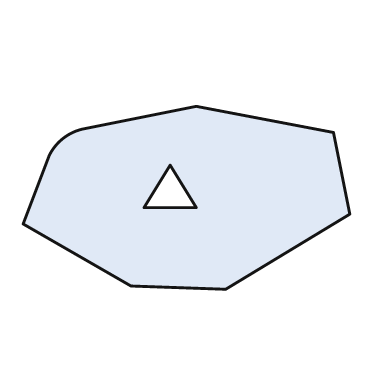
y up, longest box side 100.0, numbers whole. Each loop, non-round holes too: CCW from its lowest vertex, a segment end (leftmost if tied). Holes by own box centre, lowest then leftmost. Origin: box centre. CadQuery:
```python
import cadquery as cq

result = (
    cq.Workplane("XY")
    .moveTo(12.0, -28.0)
    .lineTo(50.0, -5.0)
    .lineTo(45.0, 20.0)
    .lineTo(3.0, 28.0)
    .lineTo(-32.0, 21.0)
    .threePointArc((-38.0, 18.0), (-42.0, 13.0))
    .lineTo(-50.0, -8.0)
    .lineTo(-17.0, -27.0)
    .close()
    .moveTo(-13.0, -3.0)
    .lineTo(3.0, -3.0)
    .lineTo(-5.0, 10.0)
    .close()
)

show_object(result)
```